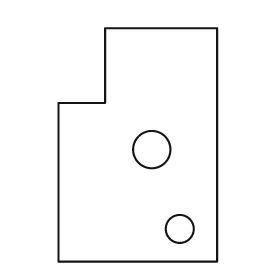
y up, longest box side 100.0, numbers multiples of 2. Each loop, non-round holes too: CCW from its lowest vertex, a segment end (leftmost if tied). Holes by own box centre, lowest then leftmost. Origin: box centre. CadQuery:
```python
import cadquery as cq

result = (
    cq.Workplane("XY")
    .moveTo(-34.0, -50.0)
    .lineTo(34.0, -50.0)
    .lineTo(34.0, 50.0)
    .lineTo(-14.0, 50.0)
    .lineTo(-14.0, 18.0)
    .lineTo(-34.0, 18.0)
    .close()
    .moveTo(18.0, -36.0)
    .circle(6.0)
    .moveTo(6.0, -2.0)
    .circle(8.0)
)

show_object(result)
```